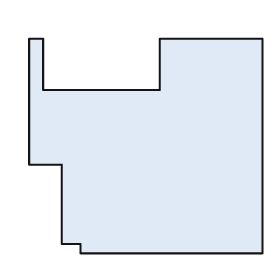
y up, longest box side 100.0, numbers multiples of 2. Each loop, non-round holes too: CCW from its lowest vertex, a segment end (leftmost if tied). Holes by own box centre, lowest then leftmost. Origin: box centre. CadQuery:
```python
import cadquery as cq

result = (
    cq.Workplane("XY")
    .moveTo(-28.0, -46.0)
    .lineTo(50.0, -46.0)
    .lineTo(50.0, 46.0)
    .lineTo(6.0, 46.0)
    .lineTo(6.0, 24.0)
    .lineTo(-44.0, 24.0)
    .lineTo(-44.0, 46.0)
    .lineTo(-50.0, 46.0)
    .lineTo(-50.0, -8.0)
    .lineTo(-36.0, -8.0)
    .lineTo(-36.0, -42.0)
    .lineTo(-28.0, -42.0)
    .close()
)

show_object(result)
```